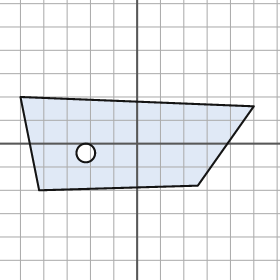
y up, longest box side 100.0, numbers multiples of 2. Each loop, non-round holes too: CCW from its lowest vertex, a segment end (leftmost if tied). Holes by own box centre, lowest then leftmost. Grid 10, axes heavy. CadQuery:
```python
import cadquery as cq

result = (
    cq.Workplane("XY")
    .moveTo(-42.0, -20.0)
    .lineTo(26.0, -18.0)
    .lineTo(50.0, 16.0)
    .lineTo(-50.0, 20.0)
    .close()
    .moveTo(-22.0, -4.0)
    .circle(4.0)
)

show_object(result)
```